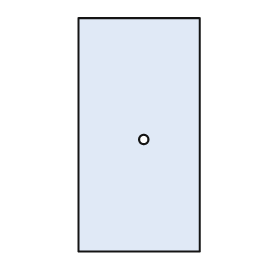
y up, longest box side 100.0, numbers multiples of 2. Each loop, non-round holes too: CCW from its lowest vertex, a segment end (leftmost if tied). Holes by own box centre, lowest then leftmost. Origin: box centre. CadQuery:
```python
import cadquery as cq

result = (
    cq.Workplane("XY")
    .moveTo(-26.0, -50.0)
    .lineTo(26.0, -50.0)
    .lineTo(26.0, 50.0)
    .lineTo(-26.0, 50.0)
    .close()
    .moveTo(2.0, -2.0)
    .circle(2.0)
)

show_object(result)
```